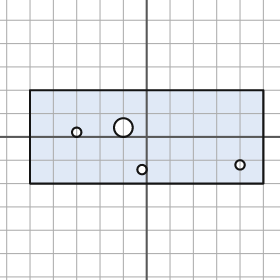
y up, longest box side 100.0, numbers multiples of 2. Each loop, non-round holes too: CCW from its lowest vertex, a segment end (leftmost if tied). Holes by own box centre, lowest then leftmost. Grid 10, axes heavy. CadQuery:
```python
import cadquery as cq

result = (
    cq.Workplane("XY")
    .moveTo(-50.0, -20.0)
    .lineTo(50.0, -20.0)
    .lineTo(50.0, 20.0)
    .lineTo(-50.0, 20.0)
    .close()
    .moveTo(-2.0, -14.0)
    .circle(2.0)
    .moveTo(40.0, -12.0)
    .circle(2.0)
    .moveTo(-30.0, 2.0)
    .circle(2.0)
    .moveTo(-10.0, 4.0)
    .circle(4.0)
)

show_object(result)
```